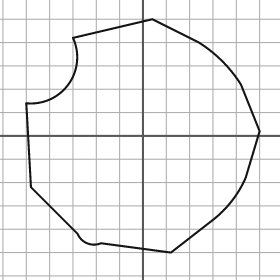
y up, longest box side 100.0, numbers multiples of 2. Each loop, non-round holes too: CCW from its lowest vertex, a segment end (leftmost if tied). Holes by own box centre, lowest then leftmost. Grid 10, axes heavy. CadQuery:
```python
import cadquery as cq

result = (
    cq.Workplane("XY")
    .moveTo(12.0, -50.0)
    .lineTo(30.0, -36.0)
    .threePointArc((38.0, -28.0), (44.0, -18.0))
    .lineTo(50.0, 2.0)
    .lineTo(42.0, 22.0)
    .threePointArc((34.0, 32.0), (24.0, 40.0))
    .lineTo(4.0, 50.0)
    .lineTo(-30.0, 42.0)
    .threePointArc((-32.0, 22.0), (-50.0, 14.0))
    .lineTo(-48.0, -22.0)
    .lineTo(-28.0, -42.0)
    .threePointArc((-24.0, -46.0), (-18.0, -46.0))
    .close()
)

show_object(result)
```